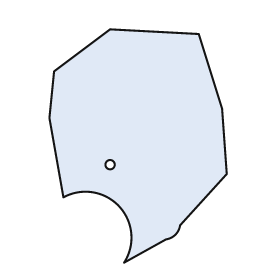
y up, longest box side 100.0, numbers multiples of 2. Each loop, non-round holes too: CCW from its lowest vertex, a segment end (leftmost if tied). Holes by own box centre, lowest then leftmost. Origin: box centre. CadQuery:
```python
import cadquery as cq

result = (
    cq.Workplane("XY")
    .moveTo(-6.0, -50.0)
    .lineTo(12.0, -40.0)
    .threePointArc((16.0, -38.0), (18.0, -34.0))
    .lineTo(38.0, -12.0)
    .lineTo(36.0, 16.0)
    .lineTo(26.0, 48.0)
    .lineTo(-12.0, 50.0)
    .lineTo(-36.0, 32.0)
    .lineTo(-38.0, 12.0)
    .lineTo(-32.0, -22.0)
    .threePointArc((-8.0, -26.0), (-6.0, -50.0))
    .close()
    .moveTo(-12.0, -8.0)
    .circle(2.0)
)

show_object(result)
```